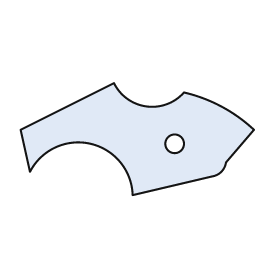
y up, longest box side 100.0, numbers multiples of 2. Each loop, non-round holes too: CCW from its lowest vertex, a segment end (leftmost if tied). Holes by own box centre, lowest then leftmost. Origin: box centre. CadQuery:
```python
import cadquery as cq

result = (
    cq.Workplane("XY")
    .moveTo(-2.0, -24.0)
    .lineTo(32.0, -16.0)
    .threePointArc((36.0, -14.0), (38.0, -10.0))
    .lineTo(50.0, 4.0)
    .threePointArc((36.0, 14.0), (20.0, 20.0))
    .threePointArc((4.0, 14.0), (-10.0, 24.0))
    .lineTo(-50.0, 4.0)
    .lineTo(-46.0, -14.0)
    .threePointArc((-20.0, -2.0), (-2.0, -24.0))
    .close()
    .moveTo(16.0, -2.0)
    .circle(4.0)
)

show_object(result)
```